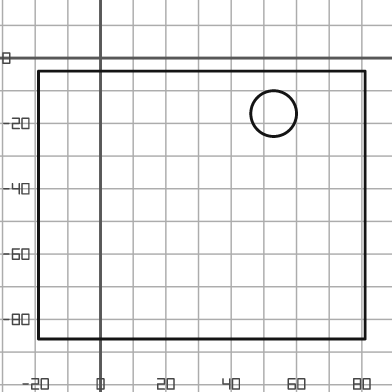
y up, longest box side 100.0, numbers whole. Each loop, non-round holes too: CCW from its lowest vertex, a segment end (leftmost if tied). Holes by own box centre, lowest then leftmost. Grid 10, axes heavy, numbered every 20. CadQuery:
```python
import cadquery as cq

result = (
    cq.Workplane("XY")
    .moveTo(-19.0, -86.0)
    .lineTo(81.0, -86.0)
    .lineTo(81.0, -4.0)
    .lineTo(-19.0, -4.0)
    .close()
    .moveTo(53.0, -17.0)
    .circle(7.0)
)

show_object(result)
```